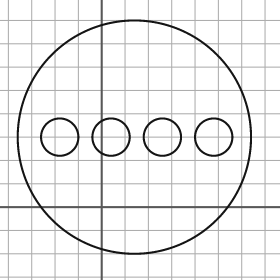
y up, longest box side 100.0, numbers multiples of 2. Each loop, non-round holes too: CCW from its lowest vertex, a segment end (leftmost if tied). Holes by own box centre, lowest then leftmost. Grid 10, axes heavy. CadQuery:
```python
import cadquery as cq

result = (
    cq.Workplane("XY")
    .moveTo(14.0, 30.0)
    .circle(50.0)
    .moveTo(-18.0, 30.0)
    .circle(8.0)
    .moveTo(4.0, 30.0)
    .circle(8.0)
    .moveTo(26.0, 30.0)
    .circle(8.0)
    .moveTo(48.0, 30.0)
    .circle(8.0)
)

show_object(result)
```